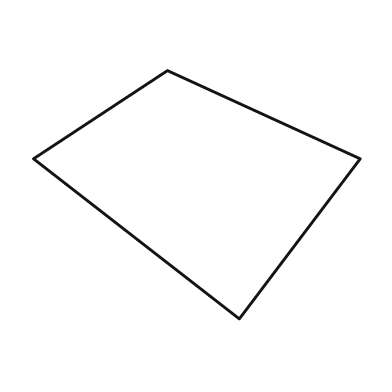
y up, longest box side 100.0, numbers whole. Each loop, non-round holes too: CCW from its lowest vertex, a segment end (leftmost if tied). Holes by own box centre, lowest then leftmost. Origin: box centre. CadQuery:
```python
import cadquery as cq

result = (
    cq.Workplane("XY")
    .moveTo(13.0, -38.0)
    .lineTo(50.0, 11.0)
    .lineTo(-9.0, 38.0)
    .lineTo(-50.0, 11.0)
    .close()
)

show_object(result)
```